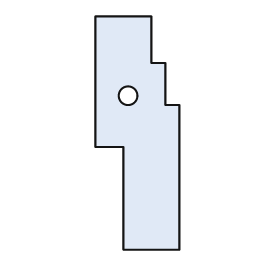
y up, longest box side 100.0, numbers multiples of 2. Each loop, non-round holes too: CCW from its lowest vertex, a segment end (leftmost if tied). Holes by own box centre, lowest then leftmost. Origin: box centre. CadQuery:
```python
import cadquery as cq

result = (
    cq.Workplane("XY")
    .moveTo(-6.0, -50.0)
    .lineTo(18.0, -50.0)
    .lineTo(18.0, 12.0)
    .lineTo(12.0, 12.0)
    .lineTo(12.0, 30.0)
    .lineTo(6.0, 30.0)
    .lineTo(6.0, 50.0)
    .lineTo(-18.0, 50.0)
    .lineTo(-18.0, -6.0)
    .lineTo(-6.0, -6.0)
    .close()
    .moveTo(-4.0, 16.0)
    .circle(4.0)
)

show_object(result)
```